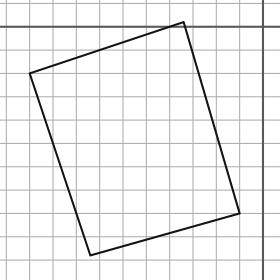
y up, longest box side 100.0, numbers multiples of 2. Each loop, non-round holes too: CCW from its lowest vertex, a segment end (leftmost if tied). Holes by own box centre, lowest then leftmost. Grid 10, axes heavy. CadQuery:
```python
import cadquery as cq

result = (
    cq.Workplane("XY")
    .moveTo(-74.0, -98.0)
    .lineTo(-10.0, -80.0)
    .lineTo(-34.0, 2.0)
    .lineTo(-100.0, -20.0)
    .close()
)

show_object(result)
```